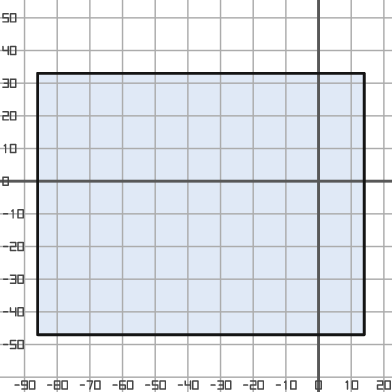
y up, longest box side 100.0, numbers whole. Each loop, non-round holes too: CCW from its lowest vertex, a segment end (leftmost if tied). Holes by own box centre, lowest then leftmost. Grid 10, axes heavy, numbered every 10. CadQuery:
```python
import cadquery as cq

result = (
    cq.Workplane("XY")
    .moveTo(-86.0, -47.0)
    .lineTo(14.0, -47.0)
    .lineTo(14.0, 33.0)
    .lineTo(-86.0, 33.0)
    .close()
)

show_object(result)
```